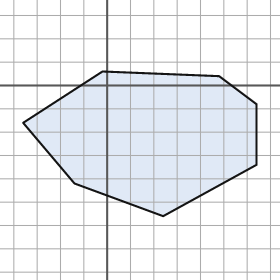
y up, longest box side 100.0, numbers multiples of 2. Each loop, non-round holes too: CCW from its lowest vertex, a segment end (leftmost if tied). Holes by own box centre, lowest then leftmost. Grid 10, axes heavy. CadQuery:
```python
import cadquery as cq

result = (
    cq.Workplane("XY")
    .moveTo(24.0, -56.0)
    .lineTo(64.0, -34.0)
    .lineTo(64.0, -8.0)
    .lineTo(48.0, 4.0)
    .lineTo(-2.0, 6.0)
    .lineTo(-36.0, -16.0)
    .lineTo(-14.0, -42.0)
    .close()
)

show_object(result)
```